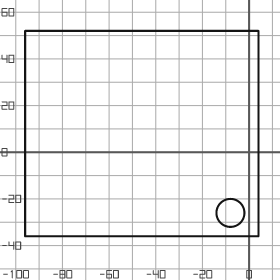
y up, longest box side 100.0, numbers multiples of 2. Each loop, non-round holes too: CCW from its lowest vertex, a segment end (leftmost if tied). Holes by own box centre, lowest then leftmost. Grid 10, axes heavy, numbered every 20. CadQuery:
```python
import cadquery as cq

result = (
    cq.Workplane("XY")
    .moveTo(-96.0, -36.0)
    .lineTo(4.0, -36.0)
    .lineTo(4.0, 52.0)
    .lineTo(-96.0, 52.0)
    .close()
    .moveTo(-8.0, -26.0)
    .circle(6.0)
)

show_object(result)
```